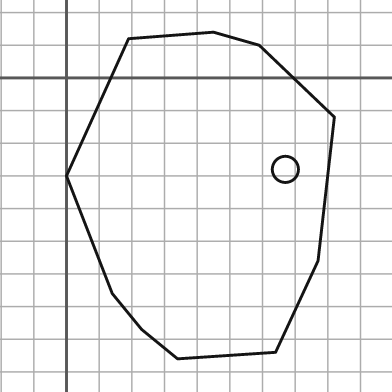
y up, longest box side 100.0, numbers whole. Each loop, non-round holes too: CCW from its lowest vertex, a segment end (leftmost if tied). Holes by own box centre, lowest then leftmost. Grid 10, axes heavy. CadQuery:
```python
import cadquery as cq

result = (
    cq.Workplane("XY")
    .moveTo(34.0, -86.0)
    .lineTo(64.0, -84.0)
    .lineTo(77.0, -56.0)
    .lineTo(82.0, -12.0)
    .lineTo(59.0, 10.0)
    .lineTo(45.0, 14.0)
    .lineTo(19.0, 12.0)
    .lineTo(0.0, -30.0)
    .lineTo(14.0, -66.0)
    .lineTo(23.0, -77.0)
    .close()
    .moveTo(67.0, -28.0)
    .circle(4.0)
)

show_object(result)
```